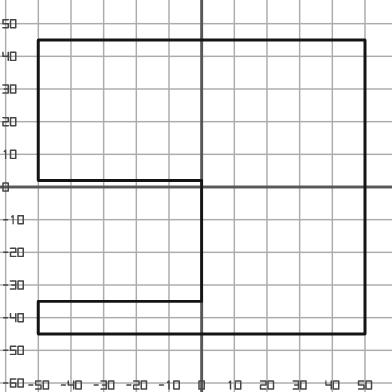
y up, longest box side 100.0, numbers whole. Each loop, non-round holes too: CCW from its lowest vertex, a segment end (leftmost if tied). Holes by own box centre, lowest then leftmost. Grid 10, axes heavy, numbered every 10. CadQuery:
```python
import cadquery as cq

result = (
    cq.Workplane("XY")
    .moveTo(-50.0, -45.0)
    .lineTo(50.0, -45.0)
    .lineTo(50.0, 45.0)
    .lineTo(-50.0, 45.0)
    .lineTo(-50.0, 2.0)
    .lineTo(0.0, 2.0)
    .lineTo(0.0, -35.0)
    .lineTo(-50.0, -35.0)
    .close()
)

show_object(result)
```